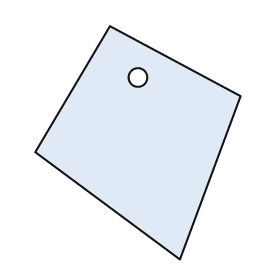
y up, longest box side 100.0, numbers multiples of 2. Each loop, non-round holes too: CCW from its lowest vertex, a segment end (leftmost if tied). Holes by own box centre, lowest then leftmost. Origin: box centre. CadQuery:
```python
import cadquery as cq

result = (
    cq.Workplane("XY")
    .moveTo(18.0, -50.0)
    .lineTo(44.0, 20.0)
    .lineTo(-12.0, 50.0)
    .lineTo(-44.0, -4.0)
    .close()
    .moveTo(0.0, 28.0)
    .circle(4.0)
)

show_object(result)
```